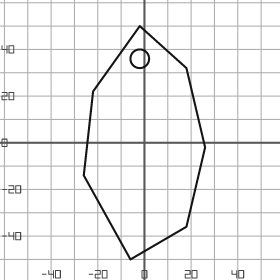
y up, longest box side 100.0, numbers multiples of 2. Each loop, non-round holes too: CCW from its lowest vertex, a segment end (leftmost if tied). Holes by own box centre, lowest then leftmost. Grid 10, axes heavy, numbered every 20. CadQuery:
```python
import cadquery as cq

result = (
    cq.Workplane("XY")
    .moveTo(-6.0, -50.0)
    .lineTo(18.0, -36.0)
    .lineTo(26.0, -2.0)
    .lineTo(18.0, 32.0)
    .lineTo(-2.0, 50.0)
    .lineTo(-22.0, 22.0)
    .lineTo(-26.0, -14.0)
    .close()
    .moveTo(-2.0, 36.0)
    .circle(4.0)
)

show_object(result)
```